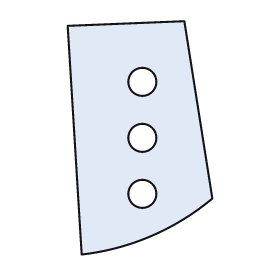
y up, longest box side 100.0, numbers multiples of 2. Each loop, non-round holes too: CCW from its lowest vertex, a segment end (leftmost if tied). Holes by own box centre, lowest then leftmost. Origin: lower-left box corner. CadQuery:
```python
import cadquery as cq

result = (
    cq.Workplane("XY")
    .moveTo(6.0, 0.0)
    .threePointArc((36.0, 8.0), (62.0, 24.0))
    .lineTo(50.0, 100.0)
    .lineTo(0.0, 98.0)
    .close()
    .moveTo(32.0, 26.0)
    .circle(6.0)
    .moveTo(32.0, 50.0)
    .circle(6.0)
    .moveTo(32.0, 74.0)
    .circle(6.0)
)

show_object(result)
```